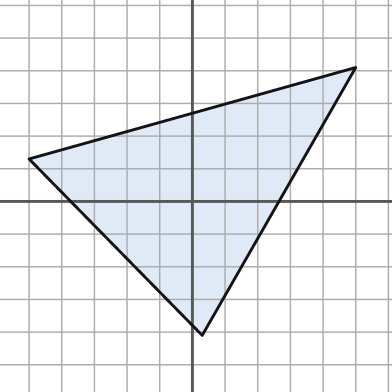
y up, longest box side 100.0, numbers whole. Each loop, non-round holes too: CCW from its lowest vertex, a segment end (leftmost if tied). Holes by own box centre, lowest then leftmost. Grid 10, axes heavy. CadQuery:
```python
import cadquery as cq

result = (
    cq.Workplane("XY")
    .moveTo(3.0, -41.0)
    .lineTo(50.0, 41.0)
    .lineTo(-50.0, 13.0)
    .close()
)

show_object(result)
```